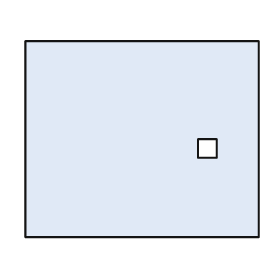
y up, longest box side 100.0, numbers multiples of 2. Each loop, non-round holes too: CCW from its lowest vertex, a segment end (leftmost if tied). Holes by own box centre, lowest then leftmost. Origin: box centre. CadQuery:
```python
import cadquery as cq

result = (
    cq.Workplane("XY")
    .moveTo(-50.0, -42.0)
    .lineTo(50.0, -42.0)
    .lineTo(50.0, 42.0)
    .lineTo(-50.0, 42.0)
    .close()
    .moveTo(24.0, -8.0)
    .lineTo(32.0, -8.0)
    .lineTo(32.0, 0.0)
    .lineTo(24.0, 0.0)
    .close()
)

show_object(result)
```